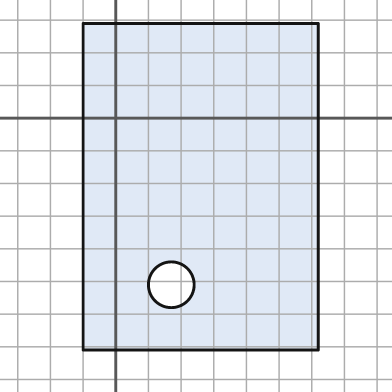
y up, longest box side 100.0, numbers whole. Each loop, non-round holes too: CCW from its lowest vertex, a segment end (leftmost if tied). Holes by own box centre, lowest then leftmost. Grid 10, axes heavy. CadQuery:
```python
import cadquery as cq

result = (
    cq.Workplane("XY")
    .moveTo(-10.0, -71.0)
    .lineTo(62.0, -71.0)
    .lineTo(62.0, 29.0)
    .lineTo(-10.0, 29.0)
    .close()
    .moveTo(17.0, -51.0)
    .circle(7.0)
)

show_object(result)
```